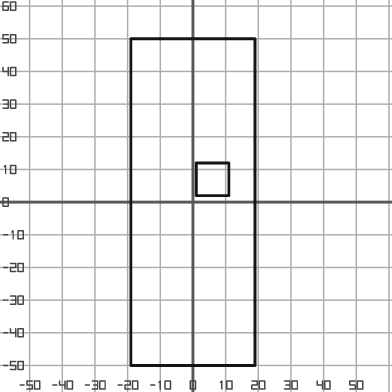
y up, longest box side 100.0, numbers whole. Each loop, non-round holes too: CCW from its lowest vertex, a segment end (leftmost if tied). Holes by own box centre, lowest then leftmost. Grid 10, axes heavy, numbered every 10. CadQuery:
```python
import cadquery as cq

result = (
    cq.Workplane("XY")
    .moveTo(-19.0, -50.0)
    .lineTo(19.0, -50.0)
    .lineTo(19.0, 50.0)
    .lineTo(-19.0, 50.0)
    .close()
    .moveTo(1.0, 2.0)
    .lineTo(11.0, 2.0)
    .lineTo(11.0, 12.0)
    .lineTo(1.0, 12.0)
    .close()
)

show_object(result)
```